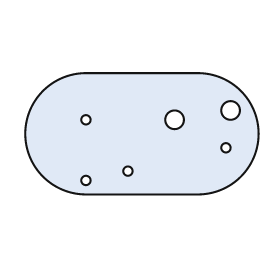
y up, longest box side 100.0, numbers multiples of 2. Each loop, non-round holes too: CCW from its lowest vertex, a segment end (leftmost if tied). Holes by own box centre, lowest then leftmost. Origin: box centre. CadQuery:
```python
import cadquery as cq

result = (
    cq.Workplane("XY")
    .moveTo(-24.0, -26.0)
    .lineTo(24.0, -26.0)
    .threePointArc((50.0, 0.0), (24.0, 26.0))
    .lineTo(-24.0, 26.0)
    .threePointArc((-50.0, 0.0), (-24.0, -26.0))
    .close()
    .moveTo(-24.0, -20.0)
    .circle(2.0)
    .moveTo(-6.0, -16.0)
    .circle(2.0)
    .moveTo(36.0, -6.0)
    .circle(2.0)
    .moveTo(-24.0, 6.0)
    .circle(2.0)
    .moveTo(14.0, 6.0)
    .circle(4.0)
    .moveTo(38.0, 10.0)
    .circle(4.0)
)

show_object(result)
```